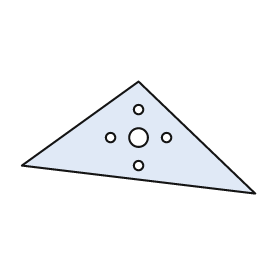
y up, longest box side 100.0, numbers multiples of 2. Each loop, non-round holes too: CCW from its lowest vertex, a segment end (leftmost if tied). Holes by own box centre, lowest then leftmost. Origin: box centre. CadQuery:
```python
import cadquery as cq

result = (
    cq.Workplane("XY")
    .moveTo(50.0, -24.0)
    .lineTo(0.0, 24.0)
    .lineTo(-50.0, -12.0)
    .close()
    .moveTo(0.0, -12.0)
    .circle(2.0)
    .moveTo(-12.0, 0.0)
    .circle(2.0)
    .moveTo(0.0, 0.0)
    .circle(4.0)
    .moveTo(12.0, 0.0)
    .circle(2.0)
    .moveTo(0.0, 12.0)
    .circle(2.0)
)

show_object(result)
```